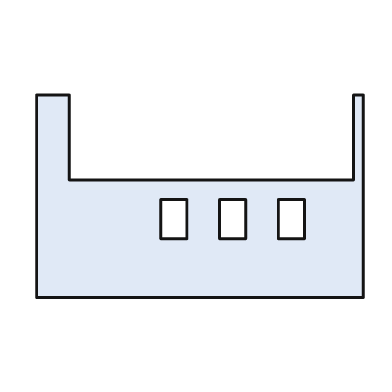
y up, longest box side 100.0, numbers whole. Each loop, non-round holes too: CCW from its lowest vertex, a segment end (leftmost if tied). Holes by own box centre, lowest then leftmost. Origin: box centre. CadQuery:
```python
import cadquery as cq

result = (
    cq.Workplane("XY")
    .moveTo(-50.0, -31.0)
    .lineTo(50.0, -31.0)
    .lineTo(50.0, 31.0)
    .lineTo(47.0, 31.0)
    .lineTo(47.0, 5.0)
    .lineTo(-40.0, 5.0)
    .lineTo(-40.0, 31.0)
    .lineTo(-50.0, 31.0)
    .close()
    .moveTo(-12.0, -13.0)
    .lineTo(-4.0, -13.0)
    .lineTo(-4.0, -1.0)
    .lineTo(-12.0, -1.0)
    .close()
    .moveTo(6.0, -13.0)
    .lineTo(14.0, -13.0)
    .lineTo(14.0, -1.0)
    .lineTo(6.0, -1.0)
    .close()
    .moveTo(24.0, -13.0)
    .lineTo(32.0, -13.0)
    .lineTo(32.0, -1.0)
    .lineTo(24.0, -1.0)
    .close()
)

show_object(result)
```